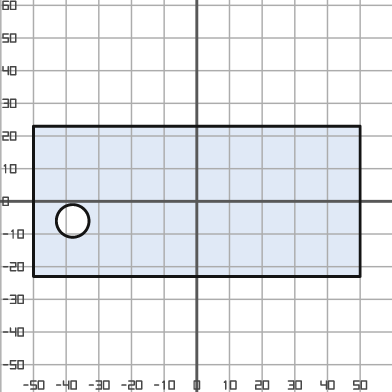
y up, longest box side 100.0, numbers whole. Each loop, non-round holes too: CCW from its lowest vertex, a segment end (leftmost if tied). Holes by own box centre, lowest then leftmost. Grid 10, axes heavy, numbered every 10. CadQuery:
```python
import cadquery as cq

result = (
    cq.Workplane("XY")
    .moveTo(-50.0, -23.0)
    .lineTo(50.0, -23.0)
    .lineTo(50.0, 23.0)
    .lineTo(-50.0, 23.0)
    .close()
    .moveTo(-38.0, -6.0)
    .circle(5.0)
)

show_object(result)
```